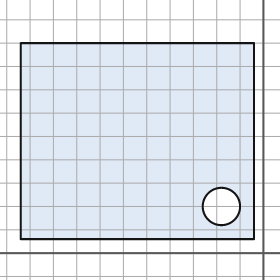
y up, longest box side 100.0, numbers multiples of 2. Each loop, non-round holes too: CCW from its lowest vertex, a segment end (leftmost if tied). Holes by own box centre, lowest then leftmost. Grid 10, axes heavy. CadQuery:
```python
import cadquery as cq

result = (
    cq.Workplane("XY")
    .moveTo(-104.0, 6.0)
    .lineTo(-4.0, 6.0)
    .lineTo(-4.0, 90.0)
    .lineTo(-104.0, 90.0)
    .close()
    .moveTo(-18.0, 20.0)
    .circle(8.0)
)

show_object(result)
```